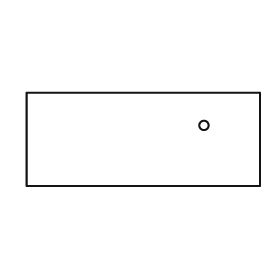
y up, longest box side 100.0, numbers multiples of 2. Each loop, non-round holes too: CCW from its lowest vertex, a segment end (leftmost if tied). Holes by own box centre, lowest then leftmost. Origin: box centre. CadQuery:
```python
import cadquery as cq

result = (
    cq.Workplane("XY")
    .moveTo(-50.0, -20.0)
    .lineTo(50.0, -20.0)
    .lineTo(50.0, 20.0)
    .lineTo(-50.0, 20.0)
    .close()
    .moveTo(26.0, 6.0)
    .circle(2.0)
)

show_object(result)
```